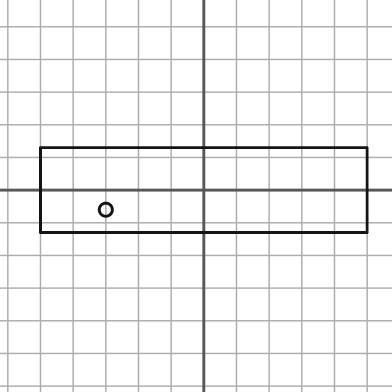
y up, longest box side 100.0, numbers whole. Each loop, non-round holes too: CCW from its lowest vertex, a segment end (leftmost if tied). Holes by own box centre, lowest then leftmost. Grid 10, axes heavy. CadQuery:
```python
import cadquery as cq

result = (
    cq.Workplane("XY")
    .moveTo(-50.0, -13.0)
    .lineTo(50.0, -13.0)
    .lineTo(50.0, 13.0)
    .lineTo(-50.0, 13.0)
    .close()
    .moveTo(-30.0, -6.0)
    .circle(2.0)
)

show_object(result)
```